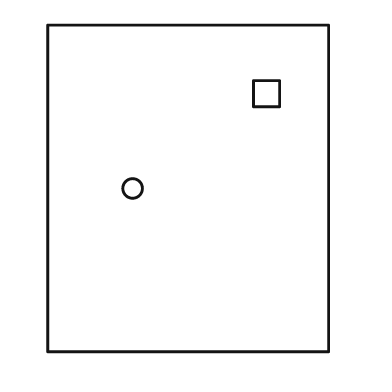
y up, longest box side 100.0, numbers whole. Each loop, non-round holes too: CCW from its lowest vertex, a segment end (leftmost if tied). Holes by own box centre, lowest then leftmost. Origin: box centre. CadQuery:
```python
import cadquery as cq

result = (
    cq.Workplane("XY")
    .moveTo(-43.0, -50.0)
    .lineTo(43.0, -50.0)
    .lineTo(43.0, 50.0)
    .lineTo(-43.0, 50.0)
    .close()
    .moveTo(-17.0, 0.0)
    .circle(3.0)
    .moveTo(20.0, 25.0)
    .lineTo(28.0, 25.0)
    .lineTo(28.0, 33.0)
    .lineTo(20.0, 33.0)
    .close()
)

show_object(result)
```